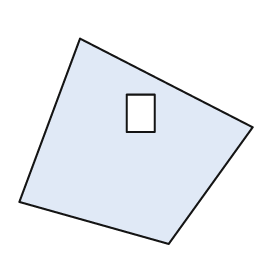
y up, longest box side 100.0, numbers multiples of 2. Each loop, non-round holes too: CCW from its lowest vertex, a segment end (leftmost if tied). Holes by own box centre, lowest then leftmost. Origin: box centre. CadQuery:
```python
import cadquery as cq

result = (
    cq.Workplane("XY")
    .moveTo(14.0, -44.0)
    .lineTo(50.0, 6.0)
    .lineTo(-24.0, 44.0)
    .lineTo(-50.0, -26.0)
    .close()
    .moveTo(-4.0, 4.0)
    .lineTo(8.0, 4.0)
    .lineTo(8.0, 20.0)
    .lineTo(-4.0, 20.0)
    .close()
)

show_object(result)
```